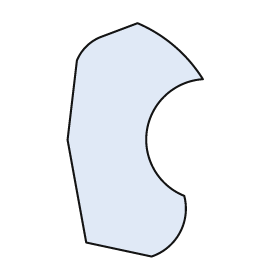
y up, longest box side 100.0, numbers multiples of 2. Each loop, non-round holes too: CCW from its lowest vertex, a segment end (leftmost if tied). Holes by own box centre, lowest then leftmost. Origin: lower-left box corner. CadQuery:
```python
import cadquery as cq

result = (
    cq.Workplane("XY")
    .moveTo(36.0, 0.0)
    .threePointArc((48.0, 10.0), (50.0, 26.0))
    .threePointArc((34.0, 54.0), (58.0, 76.0))
    .threePointArc((46.0, 90.0), (30.0, 100.0))
    .lineTo(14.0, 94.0)
    .threePointArc((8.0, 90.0), (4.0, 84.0))
    .lineTo(0.0, 50.0)
    .lineTo(8.0, 6.0)
    .close()
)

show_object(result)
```